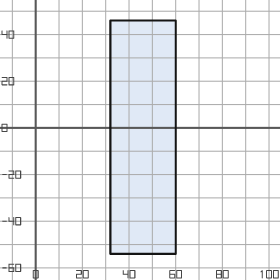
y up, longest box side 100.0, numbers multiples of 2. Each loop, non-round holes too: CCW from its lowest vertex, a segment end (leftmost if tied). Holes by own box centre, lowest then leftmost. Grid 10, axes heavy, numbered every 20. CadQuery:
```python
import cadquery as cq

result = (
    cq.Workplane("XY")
    .moveTo(32.0, -54.0)
    .lineTo(60.0, -54.0)
    .lineTo(60.0, 46.0)
    .lineTo(32.0, 46.0)
    .close()
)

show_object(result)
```